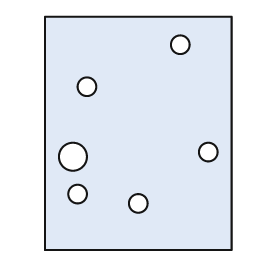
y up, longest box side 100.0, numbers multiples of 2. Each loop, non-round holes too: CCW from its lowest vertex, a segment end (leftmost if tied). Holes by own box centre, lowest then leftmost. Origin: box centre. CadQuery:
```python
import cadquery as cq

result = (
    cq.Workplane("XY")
    .moveTo(-40.0, -50.0)
    .lineTo(40.0, -50.0)
    .lineTo(40.0, 50.0)
    .lineTo(-40.0, 50.0)
    .close()
    .moveTo(0.0, -30.0)
    .circle(4.0)
    .moveTo(-26.0, -26.0)
    .circle(4.0)
    .moveTo(-28.0, -10.0)
    .circle(6.0)
    .moveTo(30.0, -8.0)
    .circle(4.0)
    .moveTo(-22.0, 20.0)
    .circle(4.0)
    .moveTo(18.0, 38.0)
    .circle(4.0)
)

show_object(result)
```